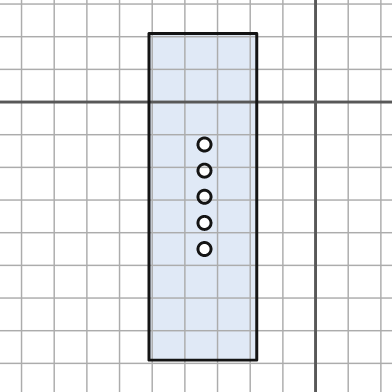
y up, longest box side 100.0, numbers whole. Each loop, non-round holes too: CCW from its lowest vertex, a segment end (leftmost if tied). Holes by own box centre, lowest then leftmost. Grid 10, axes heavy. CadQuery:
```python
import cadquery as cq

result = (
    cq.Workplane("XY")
    .moveTo(-51.0, -79.0)
    .lineTo(-18.0, -79.0)
    .lineTo(-18.0, 21.0)
    .lineTo(-51.0, 21.0)
    .close()
    .moveTo(-34.0, -45.0)
    .circle(2.0)
    .moveTo(-34.0, -37.0)
    .circle(2.0)
    .moveTo(-34.0, -29.0)
    .circle(2.0)
    .moveTo(-34.0, -21.0)
    .circle(2.0)
    .moveTo(-34.0, -13.0)
    .circle(2.0)
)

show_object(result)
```